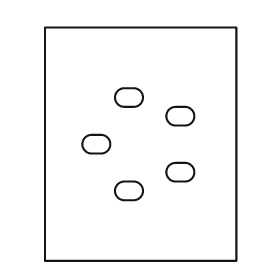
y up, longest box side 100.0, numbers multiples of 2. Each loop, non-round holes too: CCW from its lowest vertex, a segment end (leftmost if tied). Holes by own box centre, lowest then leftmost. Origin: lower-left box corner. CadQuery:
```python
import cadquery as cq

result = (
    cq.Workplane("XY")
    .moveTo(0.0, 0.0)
    .lineTo(82.0, 0.0)
    .lineTo(82.0, 100.0)
    .lineTo(0.0, 100.0)
    .close()
    .moveTo(34.0, 26.0)
    .lineTo(38.0, 26.0)
    .threePointArc((42.0, 30.0), (38.0, 34.0))
    .lineTo(34.0, 34.0)
    .threePointArc((30.0, 30.0), (34.0, 26.0))
    .close()
    .moveTo(56.0, 34.0)
    .lineTo(60.0, 34.0)
    .threePointArc((64.0, 38.0), (60.0, 42.0))
    .lineTo(56.0, 42.0)
    .threePointArc((52.0, 38.0), (56.0, 34.0))
    .close()
    .moveTo(20.0, 46.0)
    .lineTo(24.0, 46.0)
    .threePointArc((28.0, 50.0), (24.0, 54.0))
    .lineTo(20.0, 54.0)
    .threePointArc((16.0, 50.0), (20.0, 46.0))
    .close()
    .moveTo(56.0, 58.0)
    .lineTo(60.0, 58.0)
    .threePointArc((64.0, 62.0), (60.0, 66.0))
    .lineTo(56.0, 66.0)
    .threePointArc((52.0, 62.0), (56.0, 58.0))
    .close()
    .moveTo(34.0, 66.0)
    .lineTo(38.0, 66.0)
    .threePointArc((42.0, 70.0), (38.0, 74.0))
    .lineTo(34.0, 74.0)
    .threePointArc((30.0, 70.0), (34.0, 66.0))
    .close()
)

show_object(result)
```